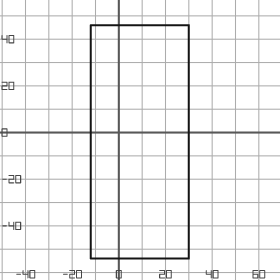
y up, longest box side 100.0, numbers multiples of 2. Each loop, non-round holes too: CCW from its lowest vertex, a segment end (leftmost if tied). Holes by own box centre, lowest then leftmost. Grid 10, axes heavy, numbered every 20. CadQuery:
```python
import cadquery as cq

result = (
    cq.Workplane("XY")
    .moveTo(-12.0, -54.0)
    .lineTo(30.0, -54.0)
    .lineTo(30.0, 46.0)
    .lineTo(-12.0, 46.0)
    .close()
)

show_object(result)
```